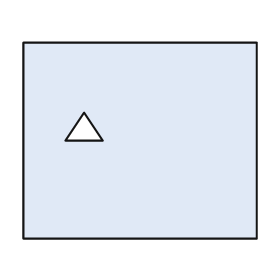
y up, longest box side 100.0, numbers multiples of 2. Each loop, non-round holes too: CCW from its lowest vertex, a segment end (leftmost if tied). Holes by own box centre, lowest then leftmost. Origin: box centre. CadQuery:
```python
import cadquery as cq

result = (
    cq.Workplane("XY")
    .moveTo(-50.0, -42.0)
    .lineTo(50.0, -42.0)
    .lineTo(50.0, 42.0)
    .lineTo(-50.0, 42.0)
    .close()
    .moveTo(-32.0, 0.0)
    .lineTo(-16.0, 0.0)
    .lineTo(-24.0, 12.0)
    .close()
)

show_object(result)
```